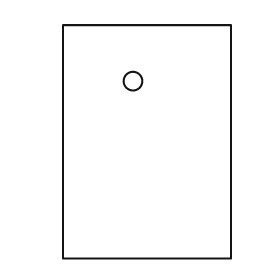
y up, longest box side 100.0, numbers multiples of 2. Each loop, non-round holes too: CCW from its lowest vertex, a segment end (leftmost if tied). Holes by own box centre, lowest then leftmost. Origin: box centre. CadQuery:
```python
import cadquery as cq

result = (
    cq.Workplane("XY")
    .moveTo(-36.0, -50.0)
    .lineTo(36.0, -50.0)
    .lineTo(36.0, 50.0)
    .lineTo(-36.0, 50.0)
    .close()
    .moveTo(-6.0, 26.0)
    .circle(4.0)
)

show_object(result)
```